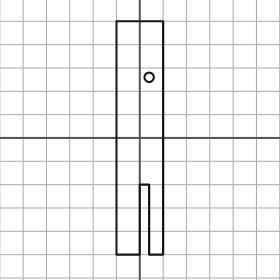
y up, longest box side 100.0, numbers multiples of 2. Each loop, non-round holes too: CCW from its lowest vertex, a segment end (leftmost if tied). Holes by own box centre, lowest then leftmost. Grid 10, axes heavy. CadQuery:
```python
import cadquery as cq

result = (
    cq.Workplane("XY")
    .moveTo(-10.0, -50.0)
    .lineTo(0.0, -50.0)
    .lineTo(0.0, -20.0)
    .lineTo(4.0, -20.0)
    .lineTo(4.0, -50.0)
    .lineTo(10.0, -50.0)
    .lineTo(10.0, 50.0)
    .lineTo(-10.0, 50.0)
    .close()
    .moveTo(4.0, 26.0)
    .circle(2.0)
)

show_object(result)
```